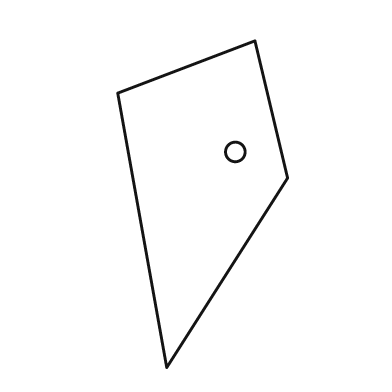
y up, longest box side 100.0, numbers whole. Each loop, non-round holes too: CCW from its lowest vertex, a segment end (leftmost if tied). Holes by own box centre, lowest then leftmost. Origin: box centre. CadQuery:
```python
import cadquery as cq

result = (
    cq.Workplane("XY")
    .moveTo(-11.0, -50.0)
    .lineTo(26.0, 8.0)
    .lineTo(16.0, 50.0)
    .lineTo(-26.0, 34.0)
    .close()
    .moveTo(10.0, 16.0)
    .circle(3.0)
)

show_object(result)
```